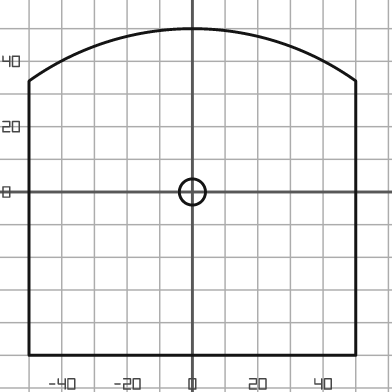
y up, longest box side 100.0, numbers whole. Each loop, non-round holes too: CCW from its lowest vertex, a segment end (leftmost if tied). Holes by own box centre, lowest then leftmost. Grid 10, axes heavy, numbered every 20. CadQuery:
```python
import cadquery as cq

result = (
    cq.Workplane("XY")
    .moveTo(-50.0, -50.0)
    .lineTo(50.0, -50.0)
    .lineTo(50.0, 34.0)
    .threePointArc((0.0, 50.0), (-50.0, 34.0))
    .close()
    .moveTo(0.0, 0.0)
    .circle(4.0)
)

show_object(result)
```